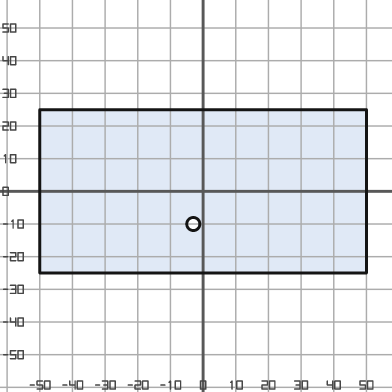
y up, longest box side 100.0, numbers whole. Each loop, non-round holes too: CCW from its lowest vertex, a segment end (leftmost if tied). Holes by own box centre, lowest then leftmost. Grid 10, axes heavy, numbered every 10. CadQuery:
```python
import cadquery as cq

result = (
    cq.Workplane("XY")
    .moveTo(-50.0, -25.0)
    .lineTo(50.0, -25.0)
    .lineTo(50.0, 25.0)
    .lineTo(-50.0, 25.0)
    .close()
    .moveTo(-3.0, -10.0)
    .circle(2.0)
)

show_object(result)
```